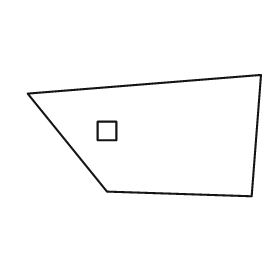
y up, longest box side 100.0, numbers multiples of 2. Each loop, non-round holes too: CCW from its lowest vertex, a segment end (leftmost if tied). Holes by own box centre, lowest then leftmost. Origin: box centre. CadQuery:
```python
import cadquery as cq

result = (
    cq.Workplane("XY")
    .moveTo(46.0, -26.0)
    .lineTo(50.0, 26.0)
    .lineTo(-50.0, 18.0)
    .lineTo(-16.0, -24.0)
    .close()
    .moveTo(-20.0, -2.0)
    .lineTo(-12.0, -2.0)
    .lineTo(-12.0, 6.0)
    .lineTo(-20.0, 6.0)
    .close()
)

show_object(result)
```